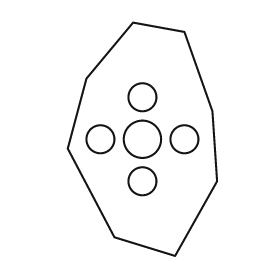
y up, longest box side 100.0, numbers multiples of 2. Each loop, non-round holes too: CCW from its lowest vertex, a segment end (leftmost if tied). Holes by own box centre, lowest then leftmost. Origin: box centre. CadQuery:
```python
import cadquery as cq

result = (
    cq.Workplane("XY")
    .moveTo(14.0, -50.0)
    .lineTo(32.0, -18.0)
    .lineTo(30.0, 12.0)
    .lineTo(18.0, 46.0)
    .lineTo(-4.0, 50.0)
    .lineTo(-24.0, 26.0)
    .lineTo(-32.0, -4.0)
    .lineTo(-12.0, -42.0)
    .close()
    .moveTo(0.0, -18.0)
    .circle(6.0)
    .moveTo(-18.0, 0.0)
    .circle(6.0)
    .moveTo(0.0, 0.0)
    .circle(8.0)
    .moveTo(18.0, 0.0)
    .circle(6.0)
    .moveTo(0.0, 18.0)
    .circle(6.0)
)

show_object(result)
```